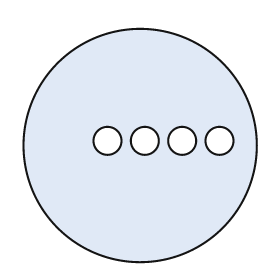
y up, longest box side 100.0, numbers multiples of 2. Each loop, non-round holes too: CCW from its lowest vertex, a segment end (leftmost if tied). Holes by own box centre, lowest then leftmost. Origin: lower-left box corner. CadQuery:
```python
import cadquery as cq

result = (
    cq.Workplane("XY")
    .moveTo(50.0, 50.0)
    .circle(50.0)
    .moveTo(36.0, 52.0)
    .circle(6.0)
    .moveTo(52.0, 52.0)
    .circle(6.0)
    .moveTo(68.0, 52.0)
    .circle(6.0)
    .moveTo(84.0, 52.0)
    .circle(6.0)
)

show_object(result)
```